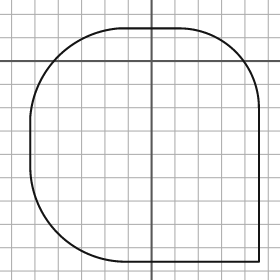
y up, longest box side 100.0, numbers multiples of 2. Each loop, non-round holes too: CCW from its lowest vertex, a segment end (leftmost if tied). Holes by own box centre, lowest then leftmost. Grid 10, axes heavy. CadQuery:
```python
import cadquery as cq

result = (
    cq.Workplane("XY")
    .moveTo(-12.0, -86.0)
    .lineTo(46.0, -86.0)
    .lineTo(46.0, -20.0)
    .threePointArc((36.0, 4.0), (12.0, 14.0))
    .lineTo(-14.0, 14.0)
    .threePointArc((-40.0, 2.0), (-52.0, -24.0))
    .lineTo(-52.0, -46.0)
    .threePointArc((-40.0, -74.0), (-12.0, -86.0))
    .close()
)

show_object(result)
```